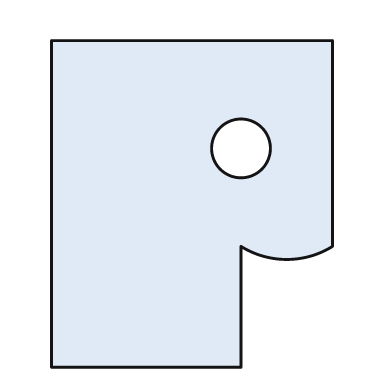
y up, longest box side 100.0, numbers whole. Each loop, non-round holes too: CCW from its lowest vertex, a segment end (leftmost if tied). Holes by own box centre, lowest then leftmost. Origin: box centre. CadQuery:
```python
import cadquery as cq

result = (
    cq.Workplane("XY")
    .moveTo(-43.0, -50.0)
    .lineTo(15.0, -50.0)
    .lineTo(15.0, -13.0)
    .threePointArc((29.0, -17.0), (43.0, -13.0))
    .lineTo(43.0, 50.0)
    .lineTo(-43.0, 50.0)
    .close()
    .moveTo(15.0, 17.0)
    .circle(9.0)
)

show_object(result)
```